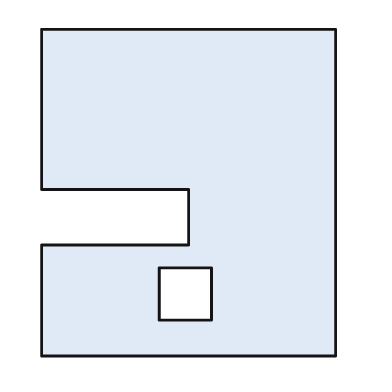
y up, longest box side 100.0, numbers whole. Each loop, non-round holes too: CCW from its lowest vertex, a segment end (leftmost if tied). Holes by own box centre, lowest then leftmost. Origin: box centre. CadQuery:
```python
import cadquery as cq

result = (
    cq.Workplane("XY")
    .moveTo(-45.0, -50.0)
    .lineTo(45.0, -50.0)
    .lineTo(45.0, 50.0)
    .lineTo(-45.0, 50.0)
    .lineTo(-45.0, 1.0)
    .lineTo(0.0, 1.0)
    .lineTo(0.0, -16.0)
    .lineTo(-45.0, -16.0)
    .close()
    .moveTo(-9.0, -39.0)
    .lineTo(7.0, -39.0)
    .lineTo(7.0, -23.0)
    .lineTo(-9.0, -23.0)
    .close()
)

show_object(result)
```